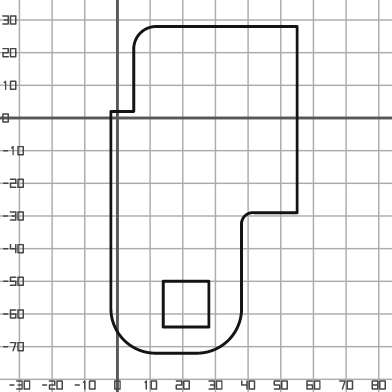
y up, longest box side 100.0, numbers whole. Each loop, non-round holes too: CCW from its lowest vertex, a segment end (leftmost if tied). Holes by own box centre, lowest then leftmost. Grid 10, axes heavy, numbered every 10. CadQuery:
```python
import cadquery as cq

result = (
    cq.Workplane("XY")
    .moveTo(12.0, -72.0)
    .lineTo(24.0, -72.0)
    .threePointArc((34.0, -68.0), (38.0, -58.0))
    .lineTo(38.0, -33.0)
    .threePointArc((39.0, -30.0), (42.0, -29.0))
    .lineTo(55.0, -29.0)
    .lineTo(55.0, 28.0)
    .lineTo(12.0, 28.0)
    .threePointArc((7.0, 26.0), (5.0, 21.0))
    .lineTo(5.0, 2.0)
    .lineTo(-2.0, 2.0)
    .lineTo(-2.0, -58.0)
    .threePointArc((2.0, -68.0), (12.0, -72.0))
    .close()
    .moveTo(14.0, -64.0)
    .lineTo(28.0, -64.0)
    .lineTo(28.0, -50.0)
    .lineTo(14.0, -50.0)
    .close()
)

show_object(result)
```